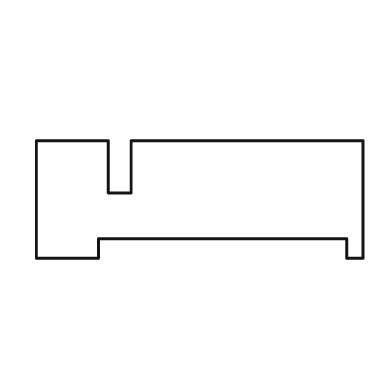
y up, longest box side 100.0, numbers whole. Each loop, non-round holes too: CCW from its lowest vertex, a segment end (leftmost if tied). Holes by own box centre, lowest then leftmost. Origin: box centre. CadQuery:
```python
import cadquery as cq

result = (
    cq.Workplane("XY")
    .moveTo(-50.0, -18.0)
    .lineTo(-31.0, -18.0)
    .lineTo(-31.0, -12.0)
    .lineTo(45.0, -12.0)
    .lineTo(45.0, -18.0)
    .lineTo(50.0, -18.0)
    .lineTo(50.0, 18.0)
    .lineTo(-21.0, 18.0)
    .lineTo(-21.0, 2.0)
    .lineTo(-28.0, 2.0)
    .lineTo(-28.0, 18.0)
    .lineTo(-50.0, 18.0)
    .close()
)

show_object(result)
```